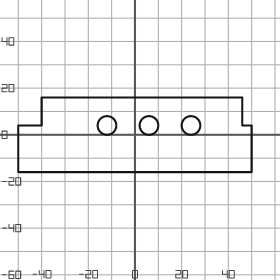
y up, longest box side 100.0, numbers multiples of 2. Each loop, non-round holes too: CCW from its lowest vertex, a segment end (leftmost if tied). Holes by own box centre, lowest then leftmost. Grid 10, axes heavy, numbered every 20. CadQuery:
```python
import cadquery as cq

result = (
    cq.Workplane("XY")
    .moveTo(-50.0, -16.0)
    .lineTo(50.0, -16.0)
    .lineTo(50.0, 4.0)
    .lineTo(46.0, 4.0)
    .lineTo(46.0, 16.0)
    .lineTo(-40.0, 16.0)
    .lineTo(-40.0, 4.0)
    .lineTo(-50.0, 4.0)
    .close()
    .moveTo(-12.0, 4.0)
    .circle(4.0)
    .moveTo(6.0, 4.0)
    .circle(4.0)
    .moveTo(24.0, 4.0)
    .circle(4.0)
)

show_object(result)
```